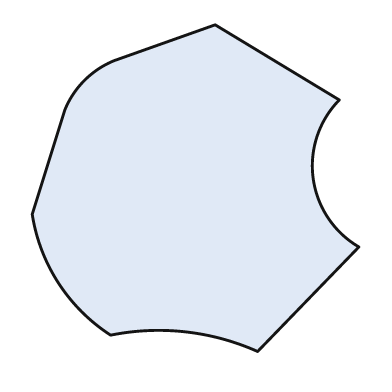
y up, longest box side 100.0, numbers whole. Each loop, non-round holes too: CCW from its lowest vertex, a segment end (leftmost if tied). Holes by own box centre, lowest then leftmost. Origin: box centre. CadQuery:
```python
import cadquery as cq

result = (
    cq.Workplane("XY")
    .moveTo(19.0, -50.0)
    .lineTo(50.0, -18.0)
    .threePointArc((36.0, 3.0), (44.0, 27.0))
    .lineTo(6.0, 50.0)
    .lineTo(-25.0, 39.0)
    .threePointArc((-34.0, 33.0), (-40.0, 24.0))
    .lineTo(-50.0, -8.0)
    .threePointArc((-42.0, -29.0), (-26.0, -45.0))
    .threePointArc((-3.0, -44.0), (19.0, -50.0))
    .close()
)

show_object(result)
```